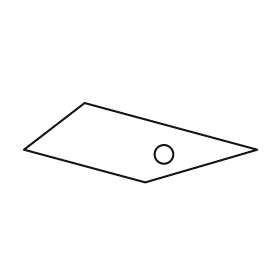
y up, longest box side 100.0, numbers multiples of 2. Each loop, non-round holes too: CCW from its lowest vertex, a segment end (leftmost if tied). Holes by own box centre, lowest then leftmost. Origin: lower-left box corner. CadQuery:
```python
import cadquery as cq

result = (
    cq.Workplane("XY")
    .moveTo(52.0, 0.0)
    .lineTo(100.0, 14.0)
    .lineTo(26.0, 34.0)
    .lineTo(0.0, 14.0)
    .close()
    .moveTo(60.0, 12.0)
    .circle(4.0)
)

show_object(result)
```